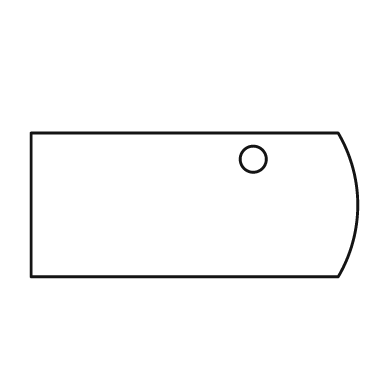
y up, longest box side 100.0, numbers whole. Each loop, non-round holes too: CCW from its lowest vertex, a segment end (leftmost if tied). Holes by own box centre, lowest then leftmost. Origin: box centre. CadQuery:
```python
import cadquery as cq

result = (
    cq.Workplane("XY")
    .moveTo(-50.0, -22.0)
    .lineTo(44.0, -22.0)
    .threePointArc((50.0, 0.0), (44.0, 22.0))
    .lineTo(-50.0, 22.0)
    .close()
    .moveTo(18.0, 14.0)
    .circle(4.0)
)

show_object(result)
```